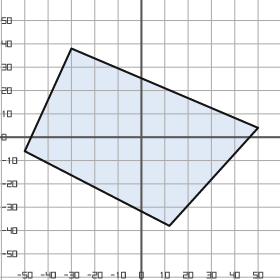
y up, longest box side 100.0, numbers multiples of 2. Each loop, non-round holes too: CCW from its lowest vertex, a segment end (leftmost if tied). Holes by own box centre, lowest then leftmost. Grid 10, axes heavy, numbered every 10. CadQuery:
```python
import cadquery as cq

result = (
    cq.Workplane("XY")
    .moveTo(12.0, -38.0)
    .lineTo(50.0, 4.0)
    .lineTo(-30.0, 38.0)
    .lineTo(-50.0, -6.0)
    .close()
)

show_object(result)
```